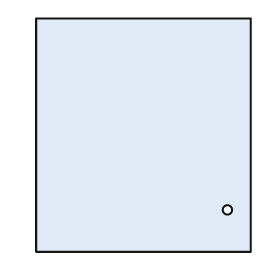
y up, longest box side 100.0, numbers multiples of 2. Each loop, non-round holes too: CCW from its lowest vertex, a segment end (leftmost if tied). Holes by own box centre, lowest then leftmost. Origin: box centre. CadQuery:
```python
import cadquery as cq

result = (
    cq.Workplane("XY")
    .moveTo(-46.0, -50.0)
    .lineTo(46.0, -50.0)
    .lineTo(46.0, 50.0)
    .lineTo(-46.0, 50.0)
    .close()
    .moveTo(36.0, -32.0)
    .circle(2.0)
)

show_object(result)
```